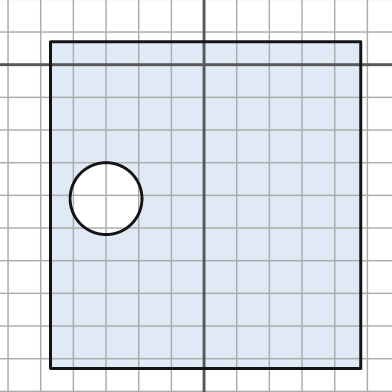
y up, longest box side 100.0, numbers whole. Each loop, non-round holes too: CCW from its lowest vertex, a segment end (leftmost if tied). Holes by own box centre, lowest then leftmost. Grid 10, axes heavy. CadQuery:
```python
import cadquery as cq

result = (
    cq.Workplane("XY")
    .moveTo(-47.0, -93.0)
    .lineTo(48.0, -93.0)
    .lineTo(48.0, 7.0)
    .lineTo(-47.0, 7.0)
    .close()
    .moveTo(-30.0, -41.0)
    .circle(11.0)
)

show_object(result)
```